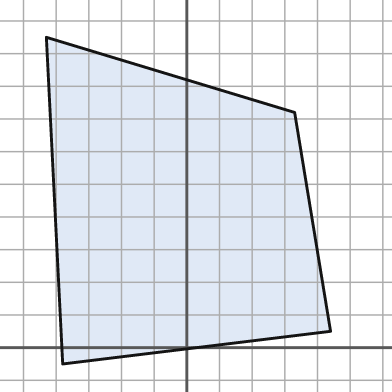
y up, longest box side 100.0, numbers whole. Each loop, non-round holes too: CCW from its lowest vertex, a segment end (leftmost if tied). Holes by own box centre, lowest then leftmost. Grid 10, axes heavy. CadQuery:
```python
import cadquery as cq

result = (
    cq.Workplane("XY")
    .moveTo(-38.0, -5.0)
    .lineTo(44.0, 5.0)
    .lineTo(33.0, 72.0)
    .lineTo(-43.0, 95.0)
    .close()
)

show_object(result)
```